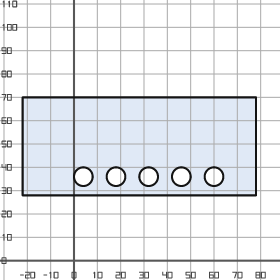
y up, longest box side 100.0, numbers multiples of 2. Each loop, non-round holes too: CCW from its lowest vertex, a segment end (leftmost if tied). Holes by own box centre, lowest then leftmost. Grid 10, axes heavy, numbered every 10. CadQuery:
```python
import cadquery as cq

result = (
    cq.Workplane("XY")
    .moveTo(-22.0, 28.0)
    .lineTo(78.0, 28.0)
    .lineTo(78.0, 70.0)
    .lineTo(-22.0, 70.0)
    .close()
    .moveTo(4.0, 36.0)
    .circle(4.0)
    .moveTo(18.0, 36.0)
    .circle(4.0)
    .moveTo(32.0, 36.0)
    .circle(4.0)
    .moveTo(46.0, 36.0)
    .circle(4.0)
    .moveTo(60.0, 36.0)
    .circle(4.0)
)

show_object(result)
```